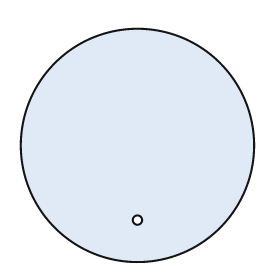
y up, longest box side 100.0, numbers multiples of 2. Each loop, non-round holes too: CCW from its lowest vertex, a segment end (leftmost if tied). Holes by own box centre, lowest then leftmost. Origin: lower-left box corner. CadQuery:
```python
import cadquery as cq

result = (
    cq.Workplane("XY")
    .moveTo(50.0, 50.0)
    .circle(50.0)
    .moveTo(50.0, 18.0)
    .circle(2.0)
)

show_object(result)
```